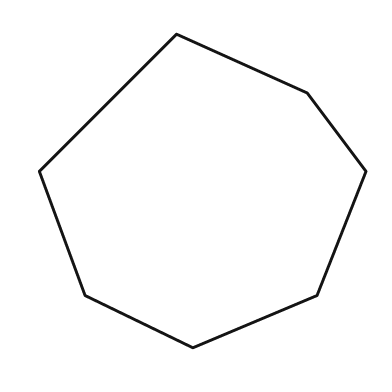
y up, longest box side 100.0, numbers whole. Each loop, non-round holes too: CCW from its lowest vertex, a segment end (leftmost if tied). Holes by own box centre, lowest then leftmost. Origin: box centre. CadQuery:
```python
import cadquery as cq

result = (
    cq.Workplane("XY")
    .moveTo(-3.0, -48.0)
    .lineTo(35.0, -32.0)
    .lineTo(50.0, 6.0)
    .lineTo(32.0, 30.0)
    .lineTo(-8.0, 48.0)
    .lineTo(-50.0, 6.0)
    .lineTo(-36.0, -32.0)
    .close()
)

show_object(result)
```